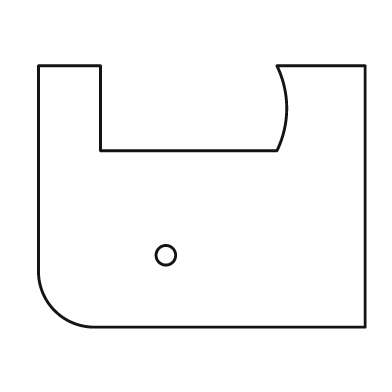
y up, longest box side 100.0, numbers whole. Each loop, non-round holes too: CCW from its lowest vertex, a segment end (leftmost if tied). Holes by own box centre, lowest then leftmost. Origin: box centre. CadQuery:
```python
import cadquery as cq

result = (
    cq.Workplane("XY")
    .moveTo(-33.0, -40.0)
    .lineTo(50.0, -40.0)
    .lineTo(50.0, 40.0)
    .lineTo(23.0, 40.0)
    .threePointArc((26.0, 27.0), (23.0, 14.0))
    .lineTo(-31.0, 14.0)
    .lineTo(-31.0, 40.0)
    .lineTo(-50.0, 40.0)
    .lineTo(-50.0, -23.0)
    .threePointArc((-45.0, -35.0), (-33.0, -40.0))
    .close()
    .moveTo(-11.0, -18.0)
    .circle(3.0)
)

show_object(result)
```